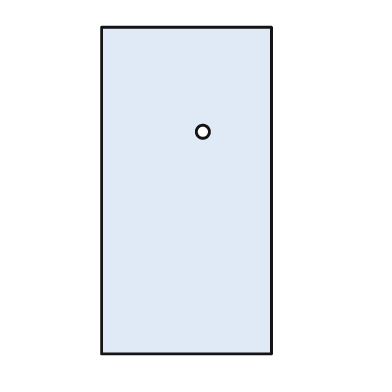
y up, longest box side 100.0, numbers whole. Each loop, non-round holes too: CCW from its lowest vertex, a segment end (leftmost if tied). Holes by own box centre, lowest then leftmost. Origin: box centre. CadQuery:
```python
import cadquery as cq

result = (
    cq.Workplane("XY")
    .moveTo(-26.0, -50.0)
    .lineTo(26.0, -50.0)
    .lineTo(26.0, 50.0)
    .lineTo(-26.0, 50.0)
    .close()
    .moveTo(5.0, 18.0)
    .circle(2.0)
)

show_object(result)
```